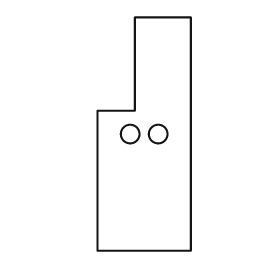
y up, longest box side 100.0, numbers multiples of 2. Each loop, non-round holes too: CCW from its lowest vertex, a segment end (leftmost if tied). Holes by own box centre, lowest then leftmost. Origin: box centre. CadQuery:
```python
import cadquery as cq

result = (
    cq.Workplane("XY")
    .moveTo(-20.0, -50.0)
    .lineTo(20.0, -50.0)
    .lineTo(20.0, 50.0)
    .lineTo(-4.0, 50.0)
    .lineTo(-4.0, 10.0)
    .lineTo(-20.0, 10.0)
    .close()
    .moveTo(-6.0, 0.0)
    .circle(4.0)
    .moveTo(6.0, 0.0)
    .circle(4.0)
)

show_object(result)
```